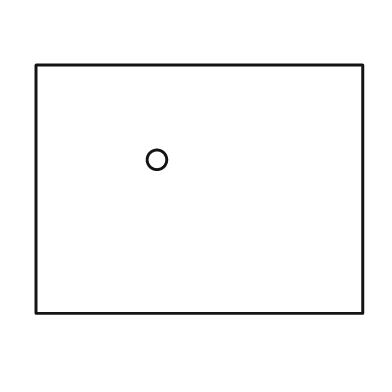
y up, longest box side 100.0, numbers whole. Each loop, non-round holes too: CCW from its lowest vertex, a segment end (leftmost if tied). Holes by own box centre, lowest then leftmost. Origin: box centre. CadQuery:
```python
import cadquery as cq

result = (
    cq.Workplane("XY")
    .moveTo(-50.0, -38.0)
    .lineTo(50.0, -38.0)
    .lineTo(50.0, 38.0)
    .lineTo(-50.0, 38.0)
    .close()
    .moveTo(-13.0, 9.0)
    .circle(3.0)
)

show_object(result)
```